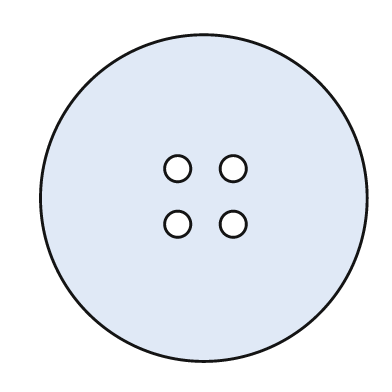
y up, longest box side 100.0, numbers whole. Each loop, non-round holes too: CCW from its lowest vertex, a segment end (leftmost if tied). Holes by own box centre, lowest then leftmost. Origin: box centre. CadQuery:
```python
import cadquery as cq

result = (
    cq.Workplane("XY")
    .moveTo(0.0, 0.0)
    .circle(50.0)
    .moveTo(-8.0, -8.0)
    .circle(4.0)
    .moveTo(9.0, -8.0)
    .circle(4.0)
    .moveTo(-8.0, 9.0)
    .circle(4.0)
    .moveTo(9.0, 9.0)
    .circle(4.0)
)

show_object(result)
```